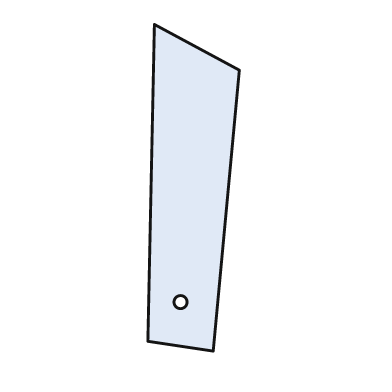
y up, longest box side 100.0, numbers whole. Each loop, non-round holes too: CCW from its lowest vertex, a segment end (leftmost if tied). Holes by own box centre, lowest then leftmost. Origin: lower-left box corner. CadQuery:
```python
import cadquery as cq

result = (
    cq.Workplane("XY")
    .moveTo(20.0, 0.0)
    .lineTo(28.0, 86.0)
    .lineTo(2.0, 100.0)
    .lineTo(0.0, 3.0)
    .close()
    .moveTo(10.0, 15.0)
    .circle(2.0)
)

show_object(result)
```